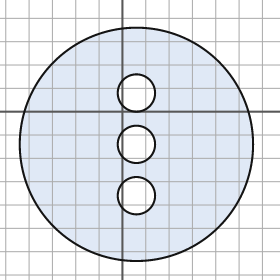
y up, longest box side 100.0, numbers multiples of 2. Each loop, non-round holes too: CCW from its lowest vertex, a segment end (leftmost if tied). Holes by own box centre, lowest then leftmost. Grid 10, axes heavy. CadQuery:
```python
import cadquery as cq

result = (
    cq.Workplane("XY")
    .moveTo(6.0, -14.0)
    .circle(50.0)
    .moveTo(6.0, -36.0)
    .circle(8.0)
    .moveTo(6.0, -14.0)
    .circle(8.0)
    .moveTo(6.0, 8.0)
    .circle(8.0)
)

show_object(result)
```